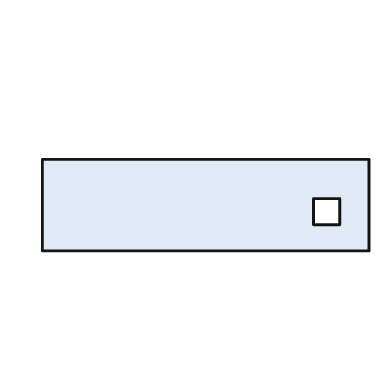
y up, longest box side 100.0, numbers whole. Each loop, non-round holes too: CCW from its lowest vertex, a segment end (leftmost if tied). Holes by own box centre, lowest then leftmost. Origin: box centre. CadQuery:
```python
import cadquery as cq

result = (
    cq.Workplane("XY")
    .moveTo(-50.0, -14.0)
    .lineTo(50.0, -14.0)
    .lineTo(50.0, 14.0)
    .lineTo(-50.0, 14.0)
    .close()
    .moveTo(33.0, -6.0)
    .lineTo(41.0, -6.0)
    .lineTo(41.0, 2.0)
    .lineTo(33.0, 2.0)
    .close()
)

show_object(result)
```